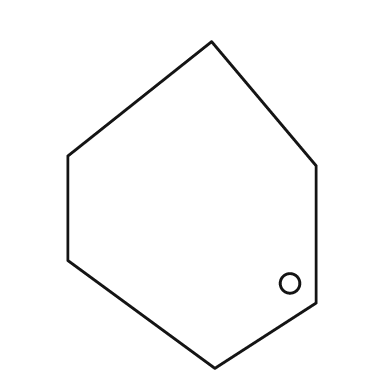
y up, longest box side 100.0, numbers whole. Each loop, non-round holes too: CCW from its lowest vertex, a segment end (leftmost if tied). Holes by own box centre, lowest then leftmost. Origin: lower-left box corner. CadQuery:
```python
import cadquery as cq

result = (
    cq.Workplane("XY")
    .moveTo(45.0, 0.0)
    .lineTo(76.0, 20.0)
    .lineTo(76.0, 62.0)
    .lineTo(44.0, 100.0)
    .lineTo(0.0, 65.0)
    .lineTo(0.0, 33.0)
    .close()
    .moveTo(68.0, 26.0)
    .circle(3.0)
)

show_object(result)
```